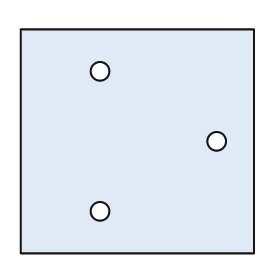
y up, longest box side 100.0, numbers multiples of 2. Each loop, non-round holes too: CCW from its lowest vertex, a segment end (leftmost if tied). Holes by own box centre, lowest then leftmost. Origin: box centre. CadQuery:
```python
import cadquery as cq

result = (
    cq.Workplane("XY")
    .moveTo(-50.0, -48.0)
    .lineTo(50.0, -48.0)
    .lineTo(50.0, 48.0)
    .lineTo(-50.0, 48.0)
    .close()
    .moveTo(-16.0, -30.0)
    .circle(4.0)
    .moveTo(34.0, 0.0)
    .circle(4.0)
    .moveTo(-16.0, 30.0)
    .circle(4.0)
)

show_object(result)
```